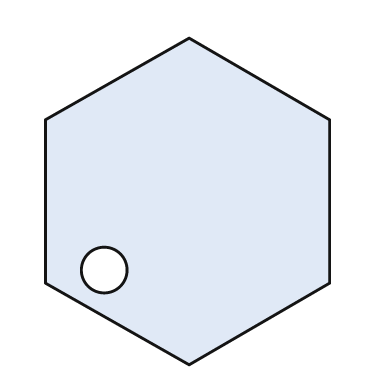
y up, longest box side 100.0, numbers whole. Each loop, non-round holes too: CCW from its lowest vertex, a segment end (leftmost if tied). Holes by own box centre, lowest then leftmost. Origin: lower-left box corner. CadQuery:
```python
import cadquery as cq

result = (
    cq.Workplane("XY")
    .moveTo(44.0, 0.0)
    .lineTo(87.0, 25.0)
    .lineTo(87.0, 75.0)
    .lineTo(44.0, 100.0)
    .lineTo(0.0, 75.0)
    .lineTo(0.0, 25.0)
    .close()
    .moveTo(18.0, 29.0)
    .circle(7.0)
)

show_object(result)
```